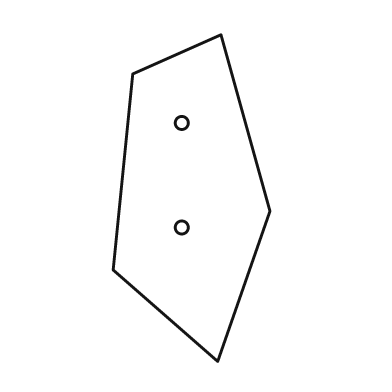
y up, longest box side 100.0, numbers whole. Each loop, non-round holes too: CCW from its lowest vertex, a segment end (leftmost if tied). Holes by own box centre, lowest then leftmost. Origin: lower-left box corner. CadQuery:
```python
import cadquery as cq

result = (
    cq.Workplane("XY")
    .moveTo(32.0, 0.0)
    .lineTo(48.0, 46.0)
    .lineTo(33.0, 100.0)
    .lineTo(6.0, 88.0)
    .lineTo(0.0, 28.0)
    .close()
    .moveTo(21.0, 41.0)
    .circle(2.0)
    .moveTo(21.0, 73.0)
    .circle(2.0)
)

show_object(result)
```